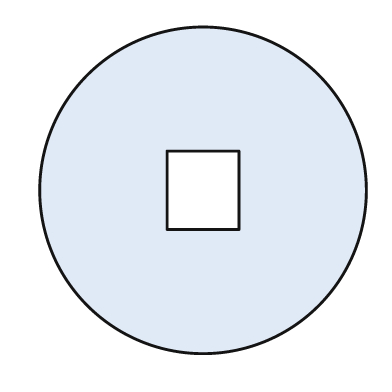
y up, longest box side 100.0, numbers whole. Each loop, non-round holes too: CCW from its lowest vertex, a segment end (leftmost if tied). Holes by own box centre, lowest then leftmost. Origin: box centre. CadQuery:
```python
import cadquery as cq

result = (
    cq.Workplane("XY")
    .moveTo(0.0, 0.0)
    .circle(50.0)
    .moveTo(-11.0, -12.0)
    .lineTo(11.0, -12.0)
    .lineTo(11.0, 12.0)
    .lineTo(-11.0, 12.0)
    .close()
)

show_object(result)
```